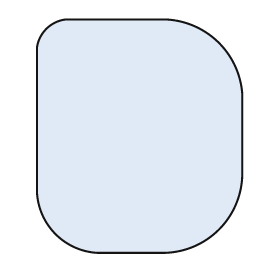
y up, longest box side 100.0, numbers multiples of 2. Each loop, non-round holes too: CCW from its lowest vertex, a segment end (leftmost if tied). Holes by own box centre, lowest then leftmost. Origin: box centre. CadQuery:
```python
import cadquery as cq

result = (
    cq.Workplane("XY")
    .moveTo(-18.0, -50.0)
    .lineTo(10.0, -50.0)
    .threePointArc((34.0, -40.0), (44.0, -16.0))
    .lineTo(44.0, 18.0)
    .threePointArc((34.0, 40.0), (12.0, 50.0))
    .lineTo(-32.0, 50.0)
    .threePointArc((-40.0, 46.0), (-44.0, 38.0))
    .lineTo(-44.0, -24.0)
    .threePointArc((-36.0, -42.0), (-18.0, -50.0))
    .close()
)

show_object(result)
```